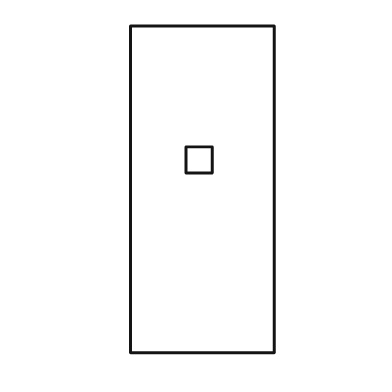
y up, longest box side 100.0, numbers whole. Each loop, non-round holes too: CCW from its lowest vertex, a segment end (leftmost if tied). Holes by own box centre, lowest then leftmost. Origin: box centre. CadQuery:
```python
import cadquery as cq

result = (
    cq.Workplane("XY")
    .moveTo(-22.0, -50.0)
    .lineTo(22.0, -50.0)
    .lineTo(22.0, 50.0)
    .lineTo(-22.0, 50.0)
    .close()
    .moveTo(-5.0, 5.0)
    .lineTo(3.0, 5.0)
    .lineTo(3.0, 13.0)
    .lineTo(-5.0, 13.0)
    .close()
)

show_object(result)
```